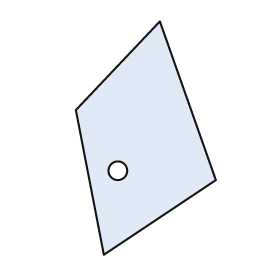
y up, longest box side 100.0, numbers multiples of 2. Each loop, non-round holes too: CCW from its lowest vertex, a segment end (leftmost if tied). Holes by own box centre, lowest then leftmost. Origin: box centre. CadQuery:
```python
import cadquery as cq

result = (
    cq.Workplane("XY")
    .moveTo(-18.0, -50.0)
    .lineTo(30.0, -18.0)
    .lineTo(6.0, 50.0)
    .lineTo(-30.0, 12.0)
    .close()
    .moveTo(-12.0, -14.0)
    .circle(4.0)
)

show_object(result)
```